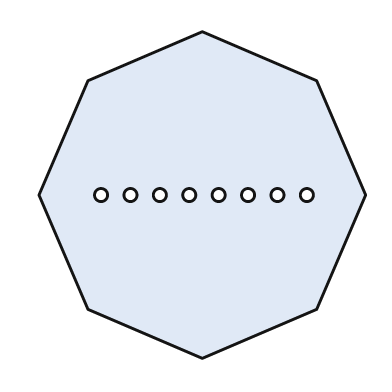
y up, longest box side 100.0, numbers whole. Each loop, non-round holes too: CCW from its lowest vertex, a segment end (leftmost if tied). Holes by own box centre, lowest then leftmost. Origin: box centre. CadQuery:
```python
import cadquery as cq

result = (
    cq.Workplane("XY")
    .moveTo(0.0, -50.0)
    .lineTo(35.0, -35.0)
    .lineTo(50.0, 0.0)
    .lineTo(35.0, 35.0)
    .lineTo(0.0, 50.0)
    .lineTo(-35.0, 35.0)
    .lineTo(-50.0, 0.0)
    .lineTo(-35.0, -35.0)
    .close()
    .moveTo(-31.0, 0.0)
    .circle(2.0)
    .moveTo(-22.0, 0.0)
    .circle(2.0)
    .moveTo(-13.0, 0.0)
    .circle(2.0)
    .moveTo(-4.0, 0.0)
    .circle(2.0)
    .moveTo(5.0, 0.0)
    .circle(2.0)
    .moveTo(14.0, 0.0)
    .circle(2.0)
    .moveTo(23.0, 0.0)
    .circle(2.0)
    .moveTo(32.0, 0.0)
    .circle(2.0)
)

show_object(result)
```